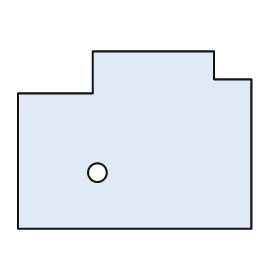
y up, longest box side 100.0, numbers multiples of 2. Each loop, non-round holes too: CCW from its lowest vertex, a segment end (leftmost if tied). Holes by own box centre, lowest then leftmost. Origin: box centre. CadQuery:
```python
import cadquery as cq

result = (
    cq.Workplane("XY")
    .moveTo(-50.0, -38.0)
    .lineTo(50.0, -38.0)
    .lineTo(50.0, 26.0)
    .lineTo(34.0, 26.0)
    .lineTo(34.0, 38.0)
    .lineTo(-18.0, 38.0)
    .lineTo(-18.0, 20.0)
    .lineTo(-50.0, 20.0)
    .close()
    .moveTo(-16.0, -14.0)
    .circle(4.0)
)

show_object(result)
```